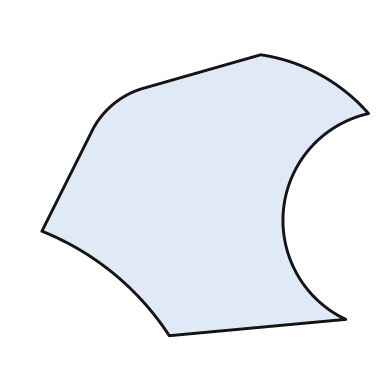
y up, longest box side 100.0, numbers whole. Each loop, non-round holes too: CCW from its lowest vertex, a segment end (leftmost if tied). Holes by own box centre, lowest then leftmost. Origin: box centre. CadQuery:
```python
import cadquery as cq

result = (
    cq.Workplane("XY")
    .moveTo(-11.0, -43.0)
    .lineTo(43.0, -38.0)
    .threePointArc((24.0, -4.0), (50.0, 25.0))
    .threePointArc((35.0, 37.0), (17.0, 43.0))
    .lineTo(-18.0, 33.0)
    .threePointArc((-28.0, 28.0), (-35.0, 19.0))
    .lineTo(-50.0, -11.0)
    .threePointArc((-28.0, -24.0), (-11.0, -43.0))
    .close()
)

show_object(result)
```